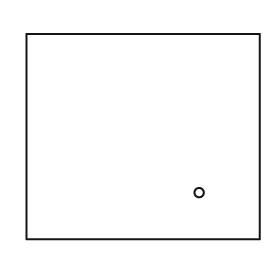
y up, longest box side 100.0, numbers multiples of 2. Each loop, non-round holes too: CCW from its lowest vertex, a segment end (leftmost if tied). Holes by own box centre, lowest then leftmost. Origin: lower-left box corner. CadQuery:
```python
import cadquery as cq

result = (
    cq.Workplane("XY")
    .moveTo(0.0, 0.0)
    .lineTo(100.0, 0.0)
    .lineTo(100.0, 88.0)
    .lineTo(0.0, 88.0)
    .close()
    .moveTo(74.0, 20.0)
    .circle(2.0)
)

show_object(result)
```